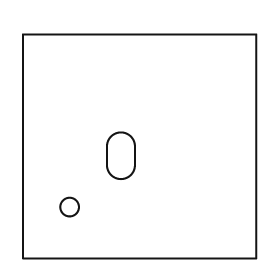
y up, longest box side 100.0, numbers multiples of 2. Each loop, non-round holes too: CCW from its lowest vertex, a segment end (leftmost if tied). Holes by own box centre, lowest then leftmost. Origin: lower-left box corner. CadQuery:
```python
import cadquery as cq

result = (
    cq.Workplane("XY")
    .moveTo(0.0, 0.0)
    .lineTo(100.0, 0.0)
    .lineTo(100.0, 96.0)
    .lineTo(0.0, 96.0)
    .close()
    .moveTo(20.0, 22.0)
    .circle(4.0)
    .moveTo(36.0, 40.0)
    .threePointArc((42.0, 34.0), (48.0, 40.0))
    .lineTo(48.0, 48.0)
    .threePointArc((42.0, 54.0), (36.0, 48.0))
    .close()
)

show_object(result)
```